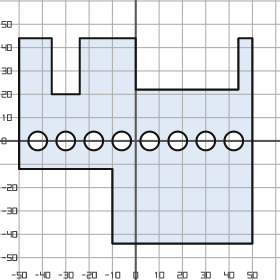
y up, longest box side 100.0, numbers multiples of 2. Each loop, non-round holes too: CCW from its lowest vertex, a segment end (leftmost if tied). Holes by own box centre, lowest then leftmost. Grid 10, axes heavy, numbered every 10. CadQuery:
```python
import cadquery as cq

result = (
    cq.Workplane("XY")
    .moveTo(-10.0, -44.0)
    .lineTo(50.0, -44.0)
    .lineTo(50.0, 44.0)
    .lineTo(44.0, 44.0)
    .lineTo(44.0, 22.0)
    .lineTo(0.0, 22.0)
    .lineTo(0.0, 44.0)
    .lineTo(-24.0, 44.0)
    .lineTo(-24.0, 20.0)
    .lineTo(-36.0, 20.0)
    .lineTo(-36.0, 44.0)
    .lineTo(-50.0, 44.0)
    .lineTo(-50.0, -12.0)
    .lineTo(-10.0, -12.0)
    .close()
    .moveTo(-42.0, 0.0)
    .circle(4.0)
    .moveTo(-30.0, 0.0)
    .circle(4.0)
    .moveTo(-18.0, 0.0)
    .circle(4.0)
    .moveTo(-6.0, 0.0)
    .circle(4.0)
    .moveTo(6.0, 0.0)
    .circle(4.0)
    .moveTo(18.0, 0.0)
    .circle(4.0)
    .moveTo(30.0, 0.0)
    .circle(4.0)
    .moveTo(42.0, 0.0)
    .circle(4.0)
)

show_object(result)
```